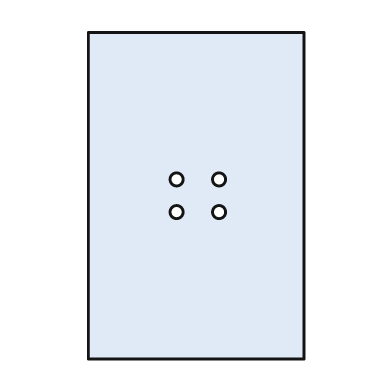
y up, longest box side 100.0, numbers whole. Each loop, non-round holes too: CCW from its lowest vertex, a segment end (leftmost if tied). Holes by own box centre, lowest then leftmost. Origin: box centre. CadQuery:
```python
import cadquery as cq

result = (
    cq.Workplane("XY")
    .moveTo(-33.0, -50.0)
    .lineTo(33.0, -50.0)
    .lineTo(33.0, 50.0)
    .lineTo(-33.0, 50.0)
    .close()
    .moveTo(-6.0, -5.0)
    .circle(2.0)
    .moveTo(7.0, -5.0)
    .circle(2.0)
    .moveTo(-6.0, 5.0)
    .circle(2.0)
    .moveTo(7.0, 5.0)
    .circle(2.0)
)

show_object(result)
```